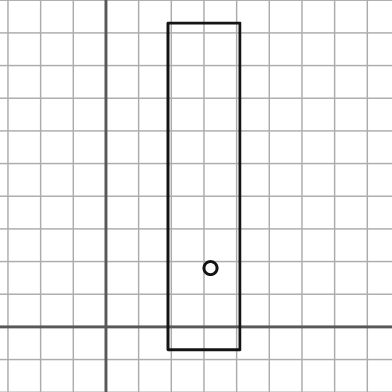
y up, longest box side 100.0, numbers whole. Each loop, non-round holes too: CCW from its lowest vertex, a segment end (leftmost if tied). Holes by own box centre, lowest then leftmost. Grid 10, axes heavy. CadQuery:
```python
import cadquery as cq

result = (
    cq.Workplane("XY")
    .moveTo(19.0, -7.0)
    .lineTo(41.0, -7.0)
    .lineTo(41.0, 93.0)
    .lineTo(19.0, 93.0)
    .close()
    .moveTo(32.0, 18.0)
    .circle(2.0)
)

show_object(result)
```